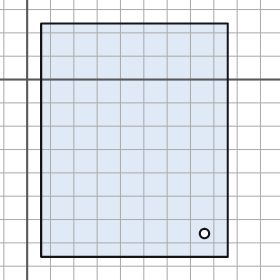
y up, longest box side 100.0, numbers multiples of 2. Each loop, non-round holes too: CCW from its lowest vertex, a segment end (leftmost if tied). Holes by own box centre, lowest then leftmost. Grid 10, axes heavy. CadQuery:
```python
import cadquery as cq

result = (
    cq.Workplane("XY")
    .moveTo(6.0, -76.0)
    .lineTo(86.0, -76.0)
    .lineTo(86.0, 24.0)
    .lineTo(6.0, 24.0)
    .close()
    .moveTo(76.0, -66.0)
    .circle(2.0)
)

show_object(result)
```